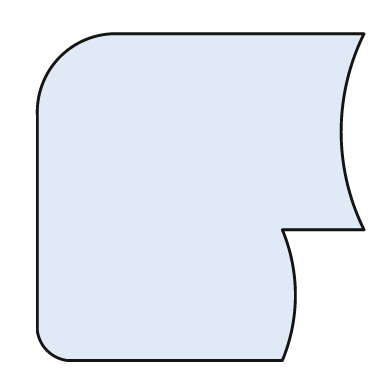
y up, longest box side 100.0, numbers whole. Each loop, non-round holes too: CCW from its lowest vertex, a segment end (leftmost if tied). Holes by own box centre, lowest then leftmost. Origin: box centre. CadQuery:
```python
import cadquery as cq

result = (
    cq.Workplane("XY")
    .moveTo(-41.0, -50.0)
    .lineTo(25.0, -50.0)
    .threePointArc((29.0, -30.0), (25.0, -10.0))
    .lineTo(50.0, -10.0)
    .threePointArc((43.0, 20.0), (50.0, 50.0))
    .lineTo(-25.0, 50.0)
    .threePointArc((-43.0, 43.0), (-50.0, 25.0))
    .lineTo(-50.0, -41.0)
    .threePointArc((-47.0, -47.0), (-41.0, -50.0))
    .close()
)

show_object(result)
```